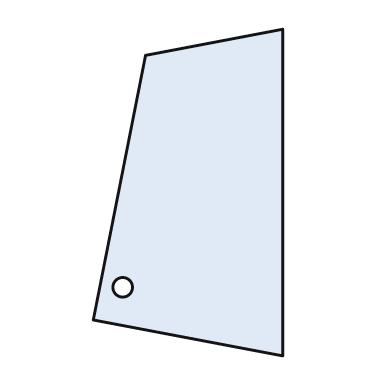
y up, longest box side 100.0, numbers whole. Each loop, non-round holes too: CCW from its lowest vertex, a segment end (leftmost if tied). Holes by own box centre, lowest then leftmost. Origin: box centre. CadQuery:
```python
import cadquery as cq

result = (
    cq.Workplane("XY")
    .moveTo(29.0, -50.0)
    .lineTo(29.0, 50.0)
    .lineTo(-13.0, 42.0)
    .lineTo(-29.0, -39.0)
    .close()
    .moveTo(-20.0, -29.0)
    .circle(3.0)
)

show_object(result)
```